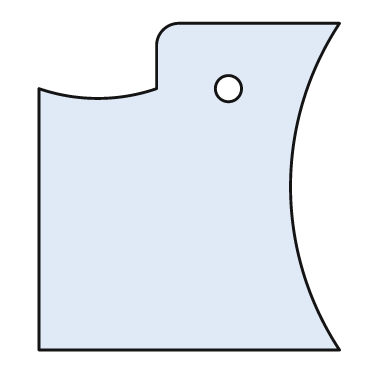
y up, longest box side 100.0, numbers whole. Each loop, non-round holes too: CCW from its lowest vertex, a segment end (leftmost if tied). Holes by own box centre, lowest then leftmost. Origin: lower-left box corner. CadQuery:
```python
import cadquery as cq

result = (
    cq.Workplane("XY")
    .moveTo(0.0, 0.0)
    .lineTo(92.0, 0.0)
    .threePointArc((77.0, 50.0), (92.0, 100.0))
    .lineTo(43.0, 100.0)
    .threePointArc((38.0, 98.0), (36.0, 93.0))
    .lineTo(36.0, 80.0)
    .threePointArc((18.0, 77.0), (0.0, 80.0))
    .close()
    .moveTo(58.0, 80.0)
    .circle(4.0)
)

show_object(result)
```